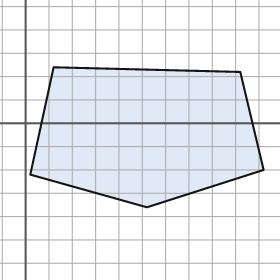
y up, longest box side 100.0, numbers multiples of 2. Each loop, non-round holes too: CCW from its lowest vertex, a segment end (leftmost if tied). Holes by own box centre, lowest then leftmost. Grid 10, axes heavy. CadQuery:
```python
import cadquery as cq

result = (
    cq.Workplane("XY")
    .moveTo(52.0, -36.0)
    .lineTo(102.0, -20.0)
    .lineTo(92.0, 22.0)
    .lineTo(12.0, 24.0)
    .lineTo(2.0, -22.0)
    .close()
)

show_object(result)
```